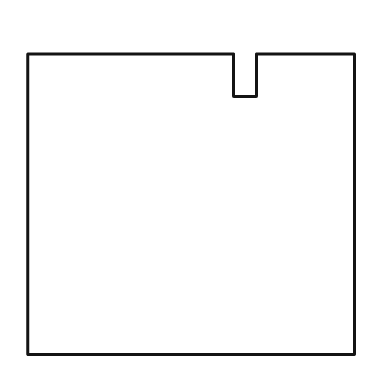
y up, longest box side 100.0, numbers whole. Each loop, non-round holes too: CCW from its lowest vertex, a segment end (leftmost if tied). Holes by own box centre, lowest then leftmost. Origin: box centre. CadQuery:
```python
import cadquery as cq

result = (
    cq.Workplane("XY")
    .moveTo(-50.0, -46.0)
    .lineTo(50.0, -46.0)
    .lineTo(50.0, 46.0)
    .lineTo(20.0, 46.0)
    .lineTo(20.0, 33.0)
    .lineTo(13.0, 33.0)
    .lineTo(13.0, 46.0)
    .lineTo(-50.0, 46.0)
    .close()
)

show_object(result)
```